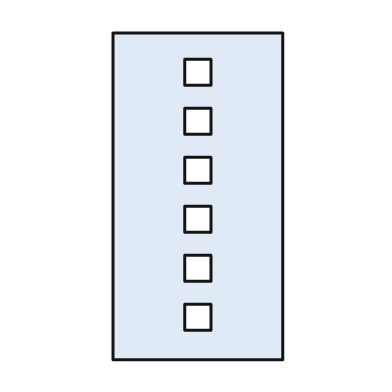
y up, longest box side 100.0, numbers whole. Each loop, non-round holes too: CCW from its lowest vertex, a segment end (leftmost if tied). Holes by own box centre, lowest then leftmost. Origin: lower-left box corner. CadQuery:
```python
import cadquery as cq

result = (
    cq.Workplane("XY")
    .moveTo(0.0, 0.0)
    .lineTo(52.0, 0.0)
    .lineTo(52.0, 100.0)
    .lineTo(0.0, 100.0)
    .close()
    .moveTo(22.0, 9.0)
    .lineTo(30.0, 9.0)
    .lineTo(30.0, 17.0)
    .lineTo(22.0, 17.0)
    .close()
    .moveTo(22.0, 24.0)
    .lineTo(30.0, 24.0)
    .lineTo(30.0, 32.0)
    .lineTo(22.0, 32.0)
    .close()
    .moveTo(22.0, 39.0)
    .lineTo(30.0, 39.0)
    .lineTo(30.0, 47.0)
    .lineTo(22.0, 47.0)
    .close()
    .moveTo(22.0, 54.0)
    .lineTo(30.0, 54.0)
    .lineTo(30.0, 62.0)
    .lineTo(22.0, 62.0)
    .close()
    .moveTo(22.0, 69.0)
    .lineTo(30.0, 69.0)
    .lineTo(30.0, 77.0)
    .lineTo(22.0, 77.0)
    .close()
    .moveTo(22.0, 84.0)
    .lineTo(30.0, 84.0)
    .lineTo(30.0, 92.0)
    .lineTo(22.0, 92.0)
    .close()
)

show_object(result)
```